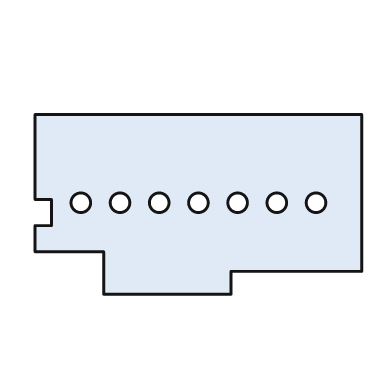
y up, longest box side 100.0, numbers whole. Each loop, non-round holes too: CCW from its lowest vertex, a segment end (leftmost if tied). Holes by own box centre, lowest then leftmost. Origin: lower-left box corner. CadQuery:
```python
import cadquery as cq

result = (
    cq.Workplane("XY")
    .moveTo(21.0, 0.0)
    .lineTo(60.0, 0.0)
    .lineTo(60.0, 7.0)
    .lineTo(100.0, 7.0)
    .lineTo(100.0, 55.0)
    .lineTo(0.0, 55.0)
    .lineTo(0.0, 29.0)
    .lineTo(5.0, 29.0)
    .lineTo(5.0, 21.0)
    .lineTo(0.0, 21.0)
    .lineTo(0.0, 13.0)
    .lineTo(21.0, 13.0)
    .close()
    .moveTo(14.0, 28.0)
    .circle(3.0)
    .moveTo(26.0, 28.0)
    .circle(3.0)
    .moveTo(38.0, 28.0)
    .circle(3.0)
    .moveTo(50.0, 28.0)
    .circle(3.0)
    .moveTo(62.0, 28.0)
    .circle(3.0)
    .moveTo(74.0, 28.0)
    .circle(3.0)
    .moveTo(86.0, 28.0)
    .circle(3.0)
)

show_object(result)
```